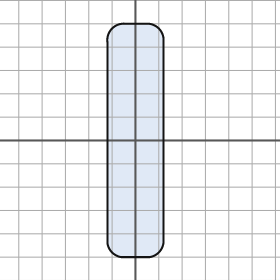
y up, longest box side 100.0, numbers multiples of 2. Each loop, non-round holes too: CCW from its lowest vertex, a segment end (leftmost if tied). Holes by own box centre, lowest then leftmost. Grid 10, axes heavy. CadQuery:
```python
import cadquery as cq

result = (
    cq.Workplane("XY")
    .moveTo(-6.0, -50.0)
    .lineTo(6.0, -50.0)
    .threePointArc((10.0, -48.0), (12.0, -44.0))
    .lineTo(12.0, 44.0)
    .threePointArc((10.0, 48.0), (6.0, 50.0))
    .lineTo(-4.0, 50.0)
    .threePointArc((-10.0, 48.0), (-12.0, 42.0))
    .lineTo(-12.0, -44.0)
    .threePointArc((-10.0, -48.0), (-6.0, -50.0))
    .close()
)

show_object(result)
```